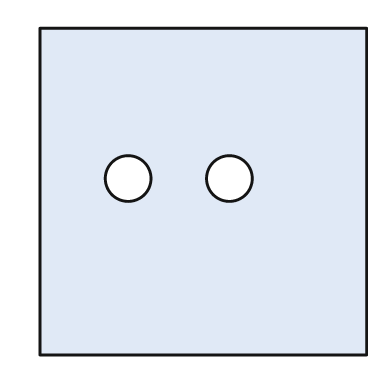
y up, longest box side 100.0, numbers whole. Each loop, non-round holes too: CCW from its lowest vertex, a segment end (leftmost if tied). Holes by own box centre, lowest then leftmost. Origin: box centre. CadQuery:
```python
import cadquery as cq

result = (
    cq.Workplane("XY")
    .moveTo(-50.0, -50.0)
    .lineTo(50.0, -50.0)
    .lineTo(50.0, 50.0)
    .lineTo(-50.0, 50.0)
    .close()
    .moveTo(-23.0, 4.0)
    .circle(7.0)
    .moveTo(8.0, 4.0)
    .circle(7.0)
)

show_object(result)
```